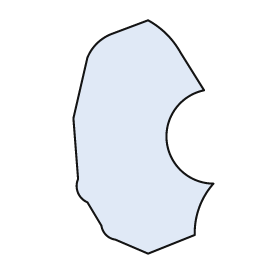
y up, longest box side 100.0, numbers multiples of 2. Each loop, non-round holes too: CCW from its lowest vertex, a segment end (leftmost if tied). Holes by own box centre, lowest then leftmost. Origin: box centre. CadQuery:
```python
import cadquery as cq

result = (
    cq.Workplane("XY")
    .moveTo(2.0, -50.0)
    .lineTo(22.0, -42.0)
    .threePointArc((24.0, -30.0), (30.0, -20.0))
    .threePointArc((10.0, -2.0), (26.0, 20.0))
    .lineTo(16.0, 36.0)
    .threePointArc((10.0, 44.0), (2.0, 50.0))
    .lineTo(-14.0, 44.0)
    .threePointArc((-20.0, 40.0), (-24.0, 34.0))
    .lineTo(-30.0, 8.0)
    .lineTo(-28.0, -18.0)
    .threePointArc((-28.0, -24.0), (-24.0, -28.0))
    .lineTo(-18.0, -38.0)
    .threePointArc((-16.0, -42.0), (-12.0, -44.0))
    .close()
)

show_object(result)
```